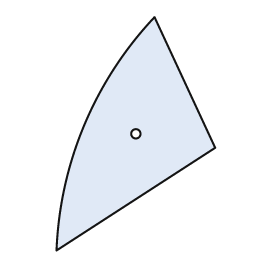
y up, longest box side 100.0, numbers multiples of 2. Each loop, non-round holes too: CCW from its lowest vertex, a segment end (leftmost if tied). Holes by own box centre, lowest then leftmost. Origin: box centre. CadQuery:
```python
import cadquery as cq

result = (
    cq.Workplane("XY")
    .moveTo(-34.0, -50.0)
    .lineTo(34.0, -6.0)
    .lineTo(8.0, 50.0)
    .threePointArc((-22.0, 4.0), (-34.0, -50.0))
    .close()
    .moveTo(0.0, 0.0)
    .circle(2.0)
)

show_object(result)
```